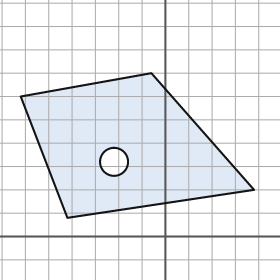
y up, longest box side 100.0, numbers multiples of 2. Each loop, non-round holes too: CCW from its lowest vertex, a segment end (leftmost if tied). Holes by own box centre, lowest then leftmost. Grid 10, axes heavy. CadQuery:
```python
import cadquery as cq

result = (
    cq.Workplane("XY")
    .moveTo(-42.0, 8.0)
    .lineTo(38.0, 20.0)
    .lineTo(-6.0, 70.0)
    .lineTo(-62.0, 60.0)
    .close()
    .moveTo(-22.0, 32.0)
    .circle(6.0)
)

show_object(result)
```